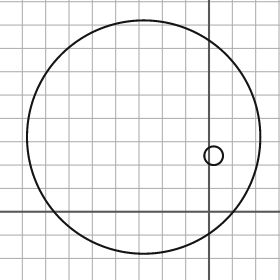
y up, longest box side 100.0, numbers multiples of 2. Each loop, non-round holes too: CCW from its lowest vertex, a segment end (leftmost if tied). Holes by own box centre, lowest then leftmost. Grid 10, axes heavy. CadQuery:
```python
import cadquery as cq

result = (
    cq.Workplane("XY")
    .moveTo(-28.0, 32.0)
    .circle(50.0)
    .moveTo(2.0, 24.0)
    .circle(4.0)
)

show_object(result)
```